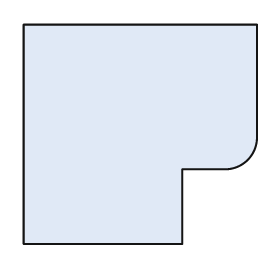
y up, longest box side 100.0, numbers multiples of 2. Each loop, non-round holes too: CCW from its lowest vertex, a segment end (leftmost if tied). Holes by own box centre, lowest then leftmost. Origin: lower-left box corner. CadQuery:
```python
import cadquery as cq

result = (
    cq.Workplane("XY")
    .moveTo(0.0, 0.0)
    .lineTo(68.0, 0.0)
    .lineTo(68.0, 32.0)
    .lineTo(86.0, 32.0)
    .threePointArc((96.0, 36.0), (100.0, 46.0))
    .lineTo(100.0, 94.0)
    .lineTo(0.0, 94.0)
    .close()
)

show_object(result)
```